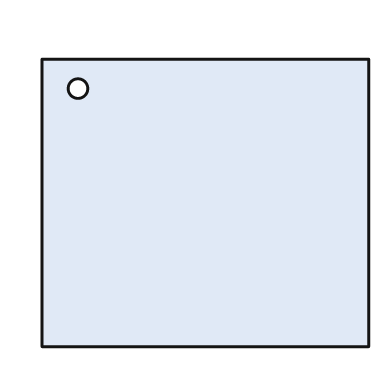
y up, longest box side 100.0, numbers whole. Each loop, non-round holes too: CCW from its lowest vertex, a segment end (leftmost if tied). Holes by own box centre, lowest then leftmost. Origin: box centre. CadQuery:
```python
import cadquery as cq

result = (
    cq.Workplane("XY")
    .moveTo(-50.0, -44.0)
    .lineTo(50.0, -44.0)
    .lineTo(50.0, 44.0)
    .lineTo(-50.0, 44.0)
    .close()
    .moveTo(-39.0, 35.0)
    .circle(3.0)
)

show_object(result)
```